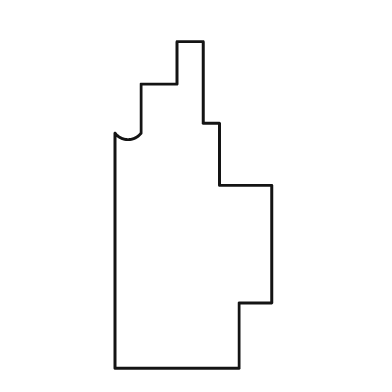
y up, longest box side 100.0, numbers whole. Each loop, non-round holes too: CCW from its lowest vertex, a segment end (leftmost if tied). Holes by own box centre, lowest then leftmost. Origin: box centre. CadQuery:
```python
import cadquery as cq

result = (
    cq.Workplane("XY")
    .moveTo(-24.0, -50.0)
    .lineTo(14.0, -50.0)
    .lineTo(14.0, -30.0)
    .lineTo(24.0, -30.0)
    .lineTo(24.0, 6.0)
    .lineTo(8.0, 6.0)
    .lineTo(8.0, 25.0)
    .lineTo(3.0, 25.0)
    .lineTo(3.0, 50.0)
    .lineTo(-5.0, 50.0)
    .lineTo(-5.0, 37.0)
    .lineTo(-16.0, 37.0)
    .lineTo(-16.0, 22.0)
    .threePointArc((-20.0, 20.0), (-24.0, 22.0))
    .close()
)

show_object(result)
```